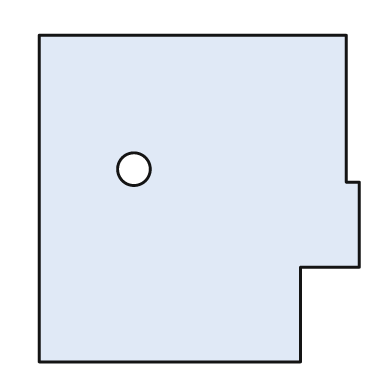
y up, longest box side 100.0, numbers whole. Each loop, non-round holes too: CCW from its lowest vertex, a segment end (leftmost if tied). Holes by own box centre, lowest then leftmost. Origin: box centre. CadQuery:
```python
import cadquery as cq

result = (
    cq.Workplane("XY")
    .moveTo(-49.0, -50.0)
    .lineTo(31.0, -50.0)
    .lineTo(31.0, -21.0)
    .lineTo(49.0, -21.0)
    .lineTo(49.0, 5.0)
    .lineTo(45.0, 5.0)
    .lineTo(45.0, 50.0)
    .lineTo(-49.0, 50.0)
    .close()
    .moveTo(-20.0, 9.0)
    .circle(5.0)
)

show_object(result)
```